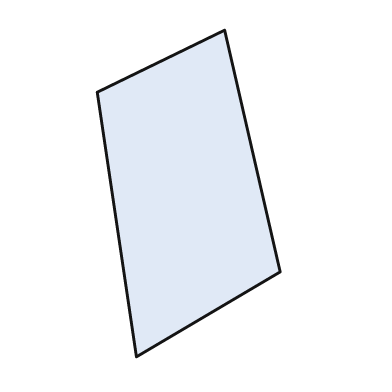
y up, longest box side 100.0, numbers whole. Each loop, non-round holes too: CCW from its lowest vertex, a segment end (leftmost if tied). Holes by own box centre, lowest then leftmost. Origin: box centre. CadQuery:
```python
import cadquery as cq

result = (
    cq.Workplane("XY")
    .moveTo(-16.0, -50.0)
    .lineTo(28.0, -24.0)
    .lineTo(11.0, 50.0)
    .lineTo(-28.0, 31.0)
    .close()
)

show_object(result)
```